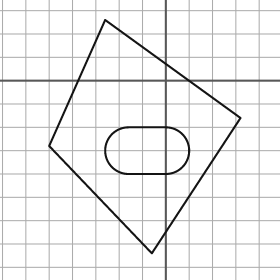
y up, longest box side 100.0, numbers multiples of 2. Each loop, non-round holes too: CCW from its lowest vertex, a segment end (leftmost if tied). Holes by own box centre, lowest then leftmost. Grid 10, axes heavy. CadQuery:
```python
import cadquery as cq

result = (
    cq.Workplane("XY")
    .moveTo(-6.0, -74.0)
    .lineTo(32.0, -16.0)
    .lineTo(-26.0, 26.0)
    .lineTo(-50.0, -28.0)
    .close()
    .moveTo(-16.0, -40.0)
    .lineTo(0.0, -40.0)
    .threePointArc((10.0, -30.0), (0.0, -20.0))
    .lineTo(-16.0, -20.0)
    .threePointArc((-26.0, -30.0), (-16.0, -40.0))
    .close()
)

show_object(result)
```